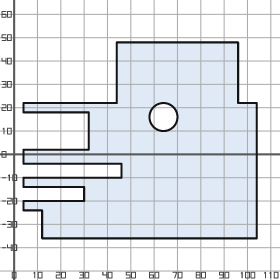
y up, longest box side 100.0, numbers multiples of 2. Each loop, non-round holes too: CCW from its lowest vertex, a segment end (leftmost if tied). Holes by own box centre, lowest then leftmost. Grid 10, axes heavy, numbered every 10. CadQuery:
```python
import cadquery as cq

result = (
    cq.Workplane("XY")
    .moveTo(12.0, -36.0)
    .lineTo(104.0, -36.0)
    .lineTo(104.0, 22.0)
    .lineTo(96.0, 22.0)
    .lineTo(96.0, 48.0)
    .lineTo(44.0, 48.0)
    .lineTo(44.0, 22.0)
    .lineTo(4.0, 22.0)
    .lineTo(4.0, 18.0)
    .lineTo(32.0, 18.0)
    .lineTo(32.0, 2.0)
    .lineTo(4.0, 2.0)
    .lineTo(4.0, -4.0)
    .lineTo(46.0, -4.0)
    .lineTo(46.0, -10.0)
    .lineTo(4.0, -10.0)
    .lineTo(4.0, -14.0)
    .lineTo(30.0, -14.0)
    .lineTo(30.0, -20.0)
    .lineTo(4.0, -20.0)
    .lineTo(4.0, -24.0)
    .lineTo(12.0, -24.0)
    .close()
    .moveTo(64.0, 16.0)
    .circle(6.0)
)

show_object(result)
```